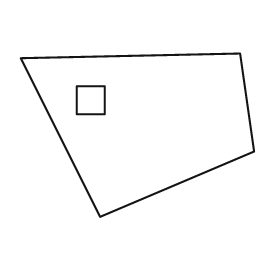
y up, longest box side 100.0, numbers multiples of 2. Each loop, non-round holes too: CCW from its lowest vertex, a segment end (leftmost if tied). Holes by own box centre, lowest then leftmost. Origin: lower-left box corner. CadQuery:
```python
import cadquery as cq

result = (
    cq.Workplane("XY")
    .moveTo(34.0, 0.0)
    .lineTo(100.0, 28.0)
    .lineTo(94.0, 70.0)
    .lineTo(0.0, 68.0)
    .close()
    .moveTo(24.0, 44.0)
    .lineTo(36.0, 44.0)
    .lineTo(36.0, 56.0)
    .lineTo(24.0, 56.0)
    .close()
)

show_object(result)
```